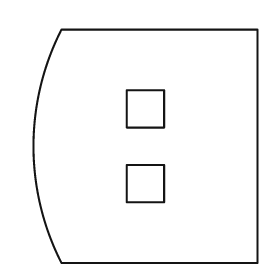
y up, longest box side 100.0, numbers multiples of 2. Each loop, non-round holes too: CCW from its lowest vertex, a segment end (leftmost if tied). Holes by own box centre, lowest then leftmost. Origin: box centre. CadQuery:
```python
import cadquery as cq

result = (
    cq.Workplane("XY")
    .moveTo(-36.0, -50.0)
    .lineTo(48.0, -50.0)
    .lineTo(48.0, 50.0)
    .lineTo(-36.0, 50.0)
    .threePointArc((-48.0, 0.0), (-36.0, -50.0))
    .close()
    .moveTo(-8.0, -24.0)
    .lineTo(8.0, -24.0)
    .lineTo(8.0, -8.0)
    .lineTo(-8.0, -8.0)
    .close()
    .moveTo(-8.0, 8.0)
    .lineTo(8.0, 8.0)
    .lineTo(8.0, 24.0)
    .lineTo(-8.0, 24.0)
    .close()
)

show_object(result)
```